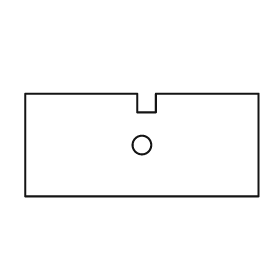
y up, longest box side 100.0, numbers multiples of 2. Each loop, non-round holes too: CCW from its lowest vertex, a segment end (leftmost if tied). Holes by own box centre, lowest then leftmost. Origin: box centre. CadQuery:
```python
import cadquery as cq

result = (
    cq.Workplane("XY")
    .moveTo(-50.0, -22.0)
    .lineTo(50.0, -22.0)
    .lineTo(50.0, 22.0)
    .lineTo(6.0, 22.0)
    .lineTo(6.0, 14.0)
    .lineTo(-2.0, 14.0)
    .lineTo(-2.0, 22.0)
    .lineTo(-50.0, 22.0)
    .close()
    .moveTo(0.0, 0.0)
    .circle(4.0)
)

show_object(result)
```